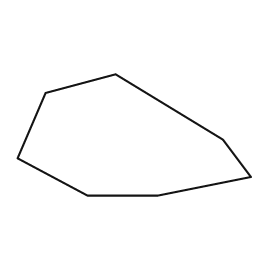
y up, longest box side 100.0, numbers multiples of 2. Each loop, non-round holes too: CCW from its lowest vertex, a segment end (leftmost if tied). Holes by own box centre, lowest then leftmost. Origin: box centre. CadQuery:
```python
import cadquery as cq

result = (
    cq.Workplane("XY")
    .moveTo(-20.0, -26.0)
    .lineTo(10.0, -26.0)
    .lineTo(50.0, -18.0)
    .lineTo(38.0, -2.0)
    .lineTo(-8.0, 26.0)
    .lineTo(-38.0, 18.0)
    .lineTo(-50.0, -10.0)
    .close()
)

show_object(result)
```